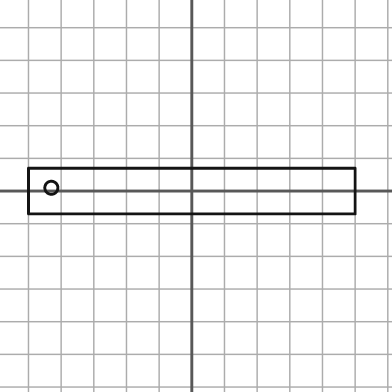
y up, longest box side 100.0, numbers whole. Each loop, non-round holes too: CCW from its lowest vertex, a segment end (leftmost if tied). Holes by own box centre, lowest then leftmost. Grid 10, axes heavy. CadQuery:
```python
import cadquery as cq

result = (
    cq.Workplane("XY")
    .moveTo(-50.0, -7.0)
    .lineTo(50.0, -7.0)
    .lineTo(50.0, 7.0)
    .lineTo(-50.0, 7.0)
    .close()
    .moveTo(-43.0, 1.0)
    .circle(2.0)
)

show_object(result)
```